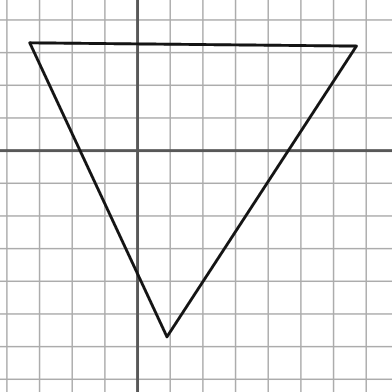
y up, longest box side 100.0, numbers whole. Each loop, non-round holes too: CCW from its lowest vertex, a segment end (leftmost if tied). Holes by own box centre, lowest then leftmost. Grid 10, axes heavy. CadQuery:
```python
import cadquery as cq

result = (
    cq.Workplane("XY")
    .moveTo(9.0, -57.0)
    .lineTo(67.0, 32.0)
    .lineTo(-33.0, 33.0)
    .close()
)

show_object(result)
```